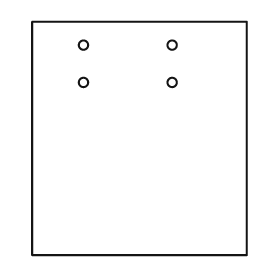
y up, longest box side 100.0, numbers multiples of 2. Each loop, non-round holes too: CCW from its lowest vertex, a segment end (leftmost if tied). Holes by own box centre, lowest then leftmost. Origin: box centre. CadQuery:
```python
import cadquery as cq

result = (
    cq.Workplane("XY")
    .moveTo(-46.0, -50.0)
    .lineTo(46.0, -50.0)
    .lineTo(46.0, 50.0)
    .lineTo(-46.0, 50.0)
    .close()
    .moveTo(-24.0, 24.0)
    .circle(2.0)
    .moveTo(14.0, 24.0)
    .circle(2.0)
    .moveTo(-24.0, 40.0)
    .circle(2.0)
    .moveTo(14.0, 40.0)
    .circle(2.0)
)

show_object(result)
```